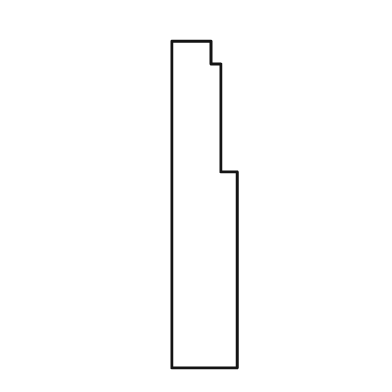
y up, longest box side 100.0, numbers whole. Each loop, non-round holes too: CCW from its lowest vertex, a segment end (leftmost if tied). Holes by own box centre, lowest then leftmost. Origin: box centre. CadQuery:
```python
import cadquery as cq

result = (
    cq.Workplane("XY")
    .moveTo(-10.0, -50.0)
    .lineTo(10.0, -50.0)
    .lineTo(10.0, 10.0)
    .lineTo(5.0, 10.0)
    .lineTo(5.0, 43.0)
    .lineTo(2.0, 43.0)
    .lineTo(2.0, 50.0)
    .lineTo(-10.0, 50.0)
    .close()
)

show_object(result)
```